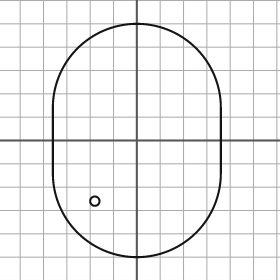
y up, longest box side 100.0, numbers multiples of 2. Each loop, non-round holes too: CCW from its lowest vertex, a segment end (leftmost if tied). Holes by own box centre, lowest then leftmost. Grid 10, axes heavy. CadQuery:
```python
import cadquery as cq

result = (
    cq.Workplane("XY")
    .moveTo(-36.0, -14.0)
    .threePointArc((0.0, -50.0), (36.0, -14.0))
    .lineTo(36.0, 14.0)
    .threePointArc((0.0, 50.0), (-36.0, 14.0))
    .close()
    .moveTo(-18.0, -26.0)
    .circle(2.0)
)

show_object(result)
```